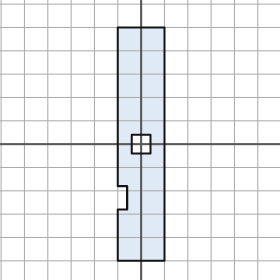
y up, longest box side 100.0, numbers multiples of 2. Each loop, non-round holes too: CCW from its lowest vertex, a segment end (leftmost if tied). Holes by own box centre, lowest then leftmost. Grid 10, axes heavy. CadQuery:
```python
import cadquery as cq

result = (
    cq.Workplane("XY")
    .moveTo(-10.0, -50.0)
    .lineTo(10.0, -50.0)
    .lineTo(10.0, 50.0)
    .lineTo(-10.0, 50.0)
    .lineTo(-10.0, -18.0)
    .lineTo(-6.0, -18.0)
    .lineTo(-6.0, -28.0)
    .lineTo(-10.0, -28.0)
    .close()
    .moveTo(-4.0, -4.0)
    .lineTo(4.0, -4.0)
    .lineTo(4.0, 4.0)
    .lineTo(-4.0, 4.0)
    .close()
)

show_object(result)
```